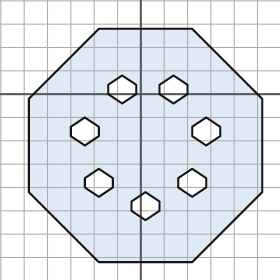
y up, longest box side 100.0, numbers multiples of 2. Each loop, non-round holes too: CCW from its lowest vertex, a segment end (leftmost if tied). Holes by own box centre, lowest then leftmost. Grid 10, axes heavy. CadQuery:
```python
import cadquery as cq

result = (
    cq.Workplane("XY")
    .moveTo(-18.0, -72.0)
    .lineTo(22.0, -72.0)
    .lineTo(52.0, -42.0)
    .lineTo(52.0, -2.0)
    .lineTo(22.0, 28.0)
    .lineTo(-18.0, 28.0)
    .lineTo(-48.0, -2.0)
    .lineTo(-48.0, -42.0)
    .close()
    .moveTo(2.0, -54.0)
    .lineTo(8.0, -50.0)
    .lineTo(8.0, -46.0)
    .lineTo(2.0, -42.0)
    .lineTo(-4.0, -46.0)
    .lineTo(-4.0, -50.0)
    .close()
    .moveTo(-18.0, -44.0)
    .lineTo(-12.0, -40.0)
    .lineTo(-12.0, -36.0)
    .lineTo(-18.0, -32.0)
    .lineTo(-24.0, -36.0)
    .lineTo(-24.0, -40.0)
    .close()
    .moveTo(22.0, -44.0)
    .lineTo(28.0, -40.0)
    .lineTo(28.0, -36.0)
    .lineTo(22.0, -32.0)
    .lineTo(16.0, -36.0)
    .lineTo(16.0, -40.0)
    .close()
    .moveTo(-24.0, -22.0)
    .lineTo(-18.0, -18.0)
    .lineTo(-18.0, -14.0)
    .lineTo(-24.0, -10.0)
    .lineTo(-30.0, -14.0)
    .lineTo(-30.0, -18.0)
    .close()
    .moveTo(28.0, -22.0)
    .lineTo(34.0, -18.0)
    .lineTo(34.0, -14.0)
    .lineTo(28.0, -10.0)
    .lineTo(22.0, -14.0)
    .lineTo(22.0, -18.0)
    .close()
    .moveTo(-8.0, -4.0)
    .lineTo(-2.0, 0.0)
    .lineTo(-2.0, 4.0)
    .lineTo(-8.0, 8.0)
    .lineTo(-14.0, 4.0)
    .lineTo(-14.0, 0.0)
    .close()
    .moveTo(14.0, -4.0)
    .lineTo(20.0, 0.0)
    .lineTo(20.0, 4.0)
    .lineTo(14.0, 8.0)
    .lineTo(8.0, 4.0)
    .lineTo(8.0, 0.0)
    .close()
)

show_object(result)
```